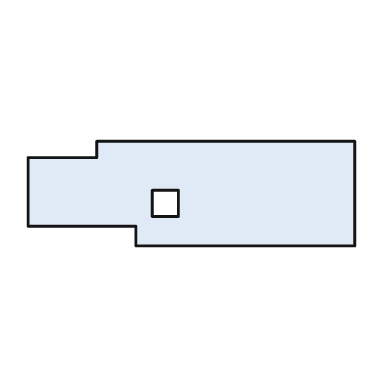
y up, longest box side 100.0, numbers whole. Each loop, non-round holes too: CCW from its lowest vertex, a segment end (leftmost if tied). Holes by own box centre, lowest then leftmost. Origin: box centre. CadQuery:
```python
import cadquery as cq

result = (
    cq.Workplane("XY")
    .moveTo(-17.0, -16.0)
    .lineTo(50.0, -16.0)
    .lineTo(50.0, 16.0)
    .lineTo(-29.0, 16.0)
    .lineTo(-29.0, 11.0)
    .lineTo(-50.0, 11.0)
    .lineTo(-50.0, -10.0)
    .lineTo(-17.0, -10.0)
    .close()
    .moveTo(-12.0, -7.0)
    .lineTo(-4.0, -7.0)
    .lineTo(-4.0, 1.0)
    .lineTo(-12.0, 1.0)
    .close()
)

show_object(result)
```